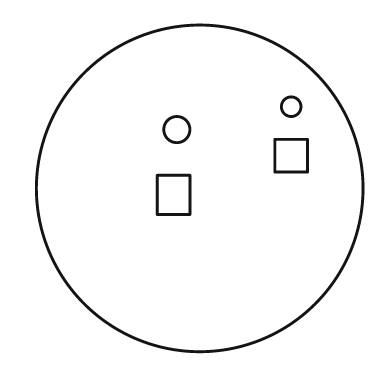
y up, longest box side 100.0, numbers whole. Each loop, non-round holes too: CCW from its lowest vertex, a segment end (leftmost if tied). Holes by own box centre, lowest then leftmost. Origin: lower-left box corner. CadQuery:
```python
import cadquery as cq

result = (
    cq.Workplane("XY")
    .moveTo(50.0, 50.0)
    .circle(50.0)
    .moveTo(37.0, 42.0)
    .lineTo(47.0, 42.0)
    .lineTo(47.0, 54.0)
    .lineTo(37.0, 54.0)
    .close()
    .moveTo(73.0, 55.0)
    .lineTo(83.0, 55.0)
    .lineTo(83.0, 65.0)
    .lineTo(73.0, 65.0)
    .close()
    .moveTo(43.0, 68.0)
    .circle(4.0)
    .moveTo(78.0, 75.0)
    .circle(3.0)
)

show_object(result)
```